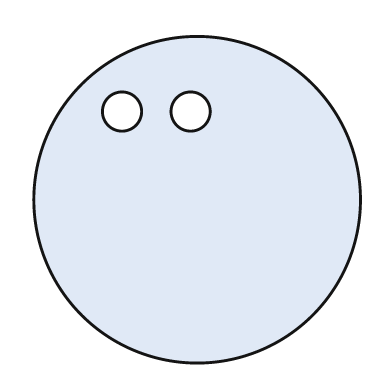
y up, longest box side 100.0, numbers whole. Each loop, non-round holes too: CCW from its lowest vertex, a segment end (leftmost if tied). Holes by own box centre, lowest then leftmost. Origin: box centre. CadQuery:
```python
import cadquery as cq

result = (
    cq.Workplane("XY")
    .moveTo(0.0, 0.0)
    .circle(50.0)
    .moveTo(-23.0, 27.0)
    .circle(6.0)
    .moveTo(-2.0, 27.0)
    .circle(6.0)
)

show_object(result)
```